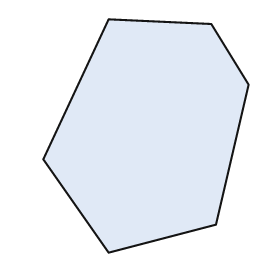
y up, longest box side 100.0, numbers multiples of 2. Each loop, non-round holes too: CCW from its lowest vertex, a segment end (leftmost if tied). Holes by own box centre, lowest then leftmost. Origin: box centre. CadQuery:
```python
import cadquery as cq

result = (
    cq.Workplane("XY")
    .moveTo(-16.0, -50.0)
    .lineTo(30.0, -38.0)
    .lineTo(44.0, 22.0)
    .lineTo(28.0, 48.0)
    .lineTo(-16.0, 50.0)
    .lineTo(-44.0, -10.0)
    .close()
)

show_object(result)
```